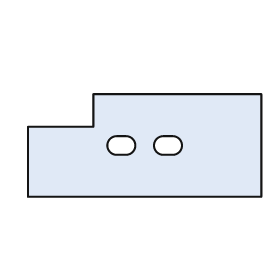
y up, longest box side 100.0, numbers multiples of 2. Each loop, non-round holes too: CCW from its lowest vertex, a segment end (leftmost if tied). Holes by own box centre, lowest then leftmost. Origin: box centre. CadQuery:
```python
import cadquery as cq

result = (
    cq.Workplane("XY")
    .moveTo(-50.0, -22.0)
    .lineTo(50.0, -22.0)
    .lineTo(50.0, 22.0)
    .lineTo(-22.0, 22.0)
    .lineTo(-22.0, 8.0)
    .lineTo(-50.0, 8.0)
    .close()
    .moveTo(-12.0, -4.0)
    .lineTo(-8.0, -4.0)
    .threePointArc((-4.0, 0.0), (-8.0, 4.0))
    .lineTo(-12.0, 4.0)
    .threePointArc((-16.0, 0.0), (-12.0, -4.0))
    .close()
    .moveTo(8.0, -4.0)
    .lineTo(12.0, -4.0)
    .threePointArc((16.0, 0.0), (12.0, 4.0))
    .lineTo(8.0, 4.0)
    .threePointArc((4.0, 0.0), (8.0, -4.0))
    .close()
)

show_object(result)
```